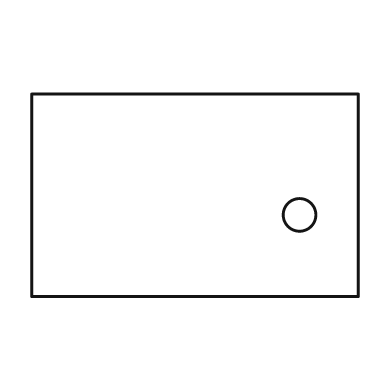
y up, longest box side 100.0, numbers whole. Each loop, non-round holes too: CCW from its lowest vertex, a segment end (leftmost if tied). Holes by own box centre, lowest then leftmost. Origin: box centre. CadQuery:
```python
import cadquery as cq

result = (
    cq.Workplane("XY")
    .moveTo(-50.0, -31.0)
    .lineTo(50.0, -31.0)
    .lineTo(50.0, 31.0)
    .lineTo(-50.0, 31.0)
    .close()
    .moveTo(32.0, -6.0)
    .circle(5.0)
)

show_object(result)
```